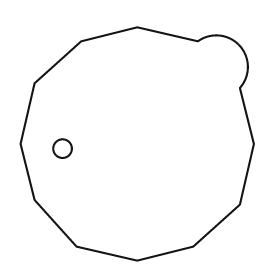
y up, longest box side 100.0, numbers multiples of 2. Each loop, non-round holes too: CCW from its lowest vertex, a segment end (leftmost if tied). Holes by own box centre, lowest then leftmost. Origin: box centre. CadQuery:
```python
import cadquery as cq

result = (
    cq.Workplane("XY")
    .moveTo(0.0, -50.0)
    .lineTo(24.0, -44.0)
    .lineTo(44.0, -26.0)
    .lineTo(50.0, 0.0)
    .lineTo(44.0, 24.0)
    .threePointArc((44.0, 42.0), (26.0, 44.0))
    .lineTo(0.0, 50.0)
    .lineTo(-24.0, 44.0)
    .lineTo(-44.0, 26.0)
    .lineTo(-50.0, 0.0)
    .lineTo(-44.0, -24.0)
    .lineTo(-26.0, -44.0)
    .close()
    .moveTo(-32.0, -2.0)
    .circle(4.0)
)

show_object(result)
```